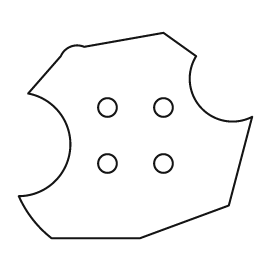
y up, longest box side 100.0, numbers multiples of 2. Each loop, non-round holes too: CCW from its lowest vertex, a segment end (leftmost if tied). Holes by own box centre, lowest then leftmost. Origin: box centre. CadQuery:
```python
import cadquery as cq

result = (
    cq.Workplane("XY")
    .moveTo(-36.0, -44.0)
    .lineTo(2.0, -44.0)
    .lineTo(40.0, -30.0)
    .lineTo(50.0, 8.0)
    .threePointArc((28.0, 12.0), (26.0, 34.0))
    .lineTo(12.0, 44.0)
    .lineTo(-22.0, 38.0)
    .threePointArc((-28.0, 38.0), (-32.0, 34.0))
    .lineTo(-46.0, 18.0)
    .threePointArc((-28.0, -6.0), (-50.0, -26.0))
    .threePointArc((-44.0, -36.0), (-36.0, -44.0))
    .close()
    .moveTo(-12.0, -12.0)
    .circle(4.0)
    .moveTo(12.0, -12.0)
    .circle(4.0)
    .moveTo(-12.0, 12.0)
    .circle(4.0)
    .moveTo(12.0, 12.0)
    .circle(4.0)
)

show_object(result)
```